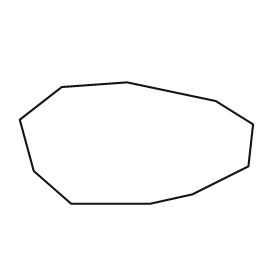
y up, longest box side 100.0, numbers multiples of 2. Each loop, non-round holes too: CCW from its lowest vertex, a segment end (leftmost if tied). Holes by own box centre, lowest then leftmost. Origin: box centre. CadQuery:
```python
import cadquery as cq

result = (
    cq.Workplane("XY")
    .moveTo(-28.0, -26.0)
    .lineTo(6.0, -26.0)
    .lineTo(24.0, -22.0)
    .lineTo(48.0, -10.0)
    .lineTo(50.0, 8.0)
    .lineTo(34.0, 18.0)
    .lineTo(-4.0, 26.0)
    .lineTo(-32.0, 24.0)
    .lineTo(-50.0, 10.0)
    .lineTo(-44.0, -12.0)
    .close()
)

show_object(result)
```